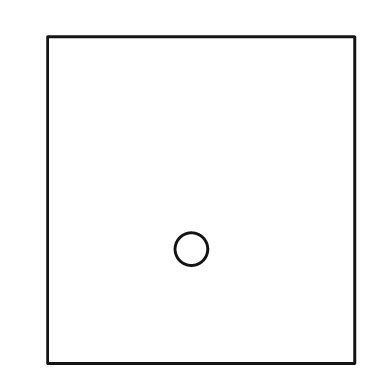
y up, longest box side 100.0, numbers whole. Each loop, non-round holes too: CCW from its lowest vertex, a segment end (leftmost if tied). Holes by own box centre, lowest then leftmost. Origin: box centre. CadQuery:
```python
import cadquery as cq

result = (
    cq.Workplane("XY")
    .moveTo(-47.0, -50.0)
    .lineTo(47.0, -50.0)
    .lineTo(47.0, 50.0)
    .lineTo(-47.0, 50.0)
    .close()
    .moveTo(-3.0, -15.0)
    .circle(5.0)
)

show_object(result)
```